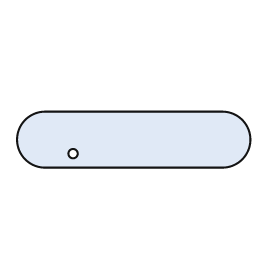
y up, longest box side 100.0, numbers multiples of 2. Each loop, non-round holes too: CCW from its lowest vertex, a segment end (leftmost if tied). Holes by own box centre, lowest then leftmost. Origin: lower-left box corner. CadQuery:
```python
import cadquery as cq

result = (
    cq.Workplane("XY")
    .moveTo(12.0, 0.0)
    .lineTo(88.0, 0.0)
    .threePointArc((100.0, 12.0), (88.0, 24.0))
    .lineTo(12.0, 24.0)
    .threePointArc((0.0, 12.0), (12.0, 0.0))
    .close()
    .moveTo(24.0, 6.0)
    .circle(2.0)
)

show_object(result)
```